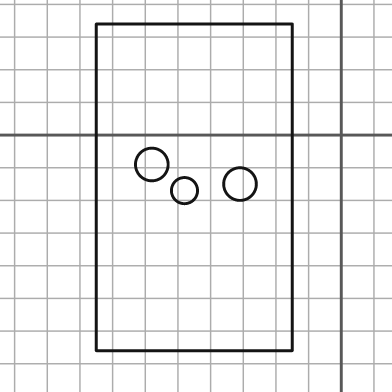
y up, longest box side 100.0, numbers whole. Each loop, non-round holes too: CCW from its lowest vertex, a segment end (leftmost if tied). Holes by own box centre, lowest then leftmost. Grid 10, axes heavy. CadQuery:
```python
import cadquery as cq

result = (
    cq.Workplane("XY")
    .moveTo(-75.0, -66.0)
    .lineTo(-15.0, -66.0)
    .lineTo(-15.0, 34.0)
    .lineTo(-75.0, 34.0)
    .close()
    .moveTo(-48.0, -17.0)
    .circle(4.0)
    .moveTo(-31.0, -15.0)
    .circle(5.0)
    .moveTo(-58.0, -9.0)
    .circle(5.0)
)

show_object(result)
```